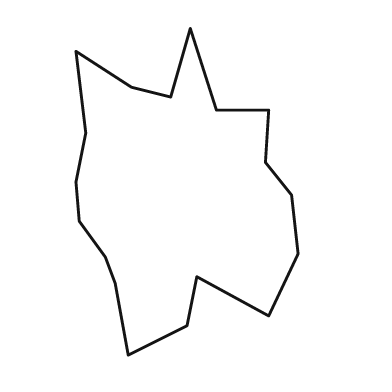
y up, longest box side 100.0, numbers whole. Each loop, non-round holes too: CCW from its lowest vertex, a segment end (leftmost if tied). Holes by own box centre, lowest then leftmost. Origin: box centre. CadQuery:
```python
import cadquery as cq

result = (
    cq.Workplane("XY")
    .moveTo(-18.0, -50.0)
    .lineTo(0.0, -41.0)
    .lineTo(3.0, -26.0)
    .lineTo(25.0, -38.0)
    .lineTo(34.0, -19.0)
    .lineTo(32.0, -1.0)
    .lineTo(24.0, 9.0)
    .lineTo(25.0, 25.0)
    .lineTo(9.0, 25.0)
    .lineTo(1.0, 50.0)
    .lineTo(-5.0, 29.0)
    .lineTo(-17.0, 32.0)
    .lineTo(-34.0, 43.0)
    .lineTo(-31.0, 18.0)
    .lineTo(-34.0, 3.0)
    .lineTo(-33.0, -9.0)
    .lineTo(-25.0, -20.0)
    .lineTo(-22.0, -28.0)
    .close()
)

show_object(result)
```